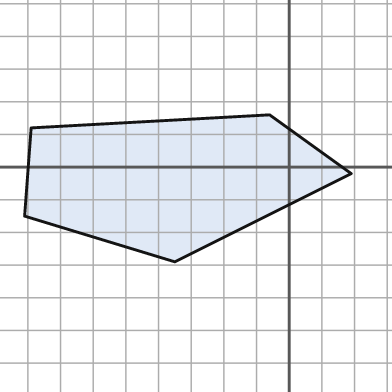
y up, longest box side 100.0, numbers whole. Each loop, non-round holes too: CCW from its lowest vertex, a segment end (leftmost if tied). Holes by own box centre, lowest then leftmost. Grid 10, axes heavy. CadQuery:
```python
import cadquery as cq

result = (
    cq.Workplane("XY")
    .moveTo(-35.0, -29.0)
    .lineTo(19.0, -2.0)
    .lineTo(-6.0, 16.0)
    .lineTo(-79.0, 12.0)
    .lineTo(-81.0, -15.0)
    .close()
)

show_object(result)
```